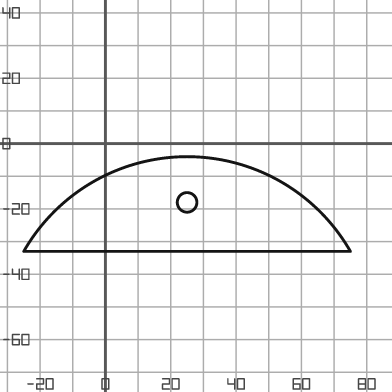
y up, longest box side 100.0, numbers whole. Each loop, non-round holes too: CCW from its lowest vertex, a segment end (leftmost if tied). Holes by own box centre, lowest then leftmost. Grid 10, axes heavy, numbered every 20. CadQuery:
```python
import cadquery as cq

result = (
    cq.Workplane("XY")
    .moveTo(-25.0, -33.0)
    .lineTo(75.0, -33.0)
    .threePointArc((25.0, -4.0), (-25.0, -33.0))
    .close()
    .moveTo(25.0, -18.0)
    .circle(3.0)
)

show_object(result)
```